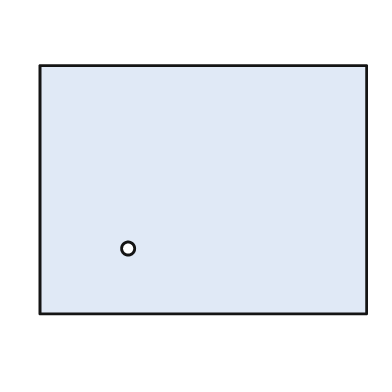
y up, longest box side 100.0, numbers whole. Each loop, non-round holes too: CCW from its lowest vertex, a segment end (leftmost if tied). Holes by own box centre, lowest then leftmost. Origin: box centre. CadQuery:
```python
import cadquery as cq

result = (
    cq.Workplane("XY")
    .moveTo(-50.0, -38.0)
    .lineTo(50.0, -38.0)
    .lineTo(50.0, 38.0)
    .lineTo(-50.0, 38.0)
    .close()
    .moveTo(-23.0, -18.0)
    .circle(2.0)
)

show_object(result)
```